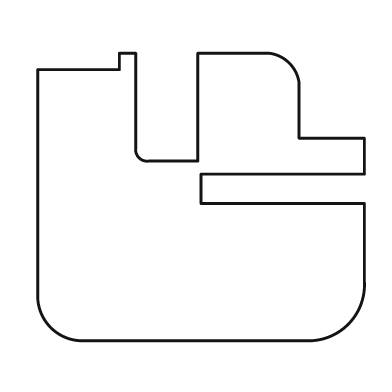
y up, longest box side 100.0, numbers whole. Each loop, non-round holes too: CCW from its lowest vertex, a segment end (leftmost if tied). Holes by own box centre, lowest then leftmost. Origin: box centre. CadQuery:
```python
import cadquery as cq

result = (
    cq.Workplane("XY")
    .moveTo(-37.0, -44.0)
    .lineTo(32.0, -44.0)
    .threePointArc((45.0, -39.0), (50.0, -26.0))
    .lineTo(50.0, -2.0)
    .lineTo(0.0, -2.0)
    .lineTo(0.0, 7.0)
    .lineTo(50.0, 7.0)
    .lineTo(50.0, 18.0)
    .lineTo(30.0, 18.0)
    .lineTo(30.0, 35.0)
    .threePointArc((27.0, 41.0), (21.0, 44.0))
    .lineTo(-1.0, 44.0)
    .lineTo(-1.0, 11.0)
    .lineTo(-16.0, 11.0)
    .threePointArc((-19.0, 12.0), (-20.0, 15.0))
    .lineTo(-20.0, 44.0)
    .lineTo(-25.0, 44.0)
    .lineTo(-25.0, 39.0)
    .lineTo(-50.0, 39.0)
    .lineTo(-50.0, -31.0)
    .threePointArc((-46.0, -40.0), (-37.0, -44.0))
    .close()
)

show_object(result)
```